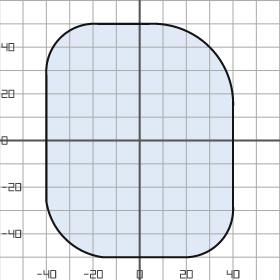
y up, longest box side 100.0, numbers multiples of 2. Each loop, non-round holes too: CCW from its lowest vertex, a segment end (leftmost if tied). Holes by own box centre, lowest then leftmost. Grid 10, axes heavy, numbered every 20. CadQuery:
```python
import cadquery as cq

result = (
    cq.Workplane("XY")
    .moveTo(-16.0, -50.0)
    .lineTo(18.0, -50.0)
    .threePointArc((34.0, -44.0), (40.0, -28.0))
    .lineTo(40.0, 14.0)
    .threePointArc((30.0, 40.0), (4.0, 50.0))
    .lineTo(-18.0, 50.0)
    .threePointArc((-34.0, 44.0), (-40.0, 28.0))
    .lineTo(-40.0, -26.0)
    .threePointArc((-32.0, -42.0), (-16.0, -50.0))
    .close()
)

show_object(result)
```